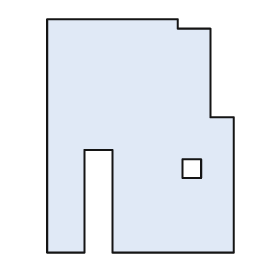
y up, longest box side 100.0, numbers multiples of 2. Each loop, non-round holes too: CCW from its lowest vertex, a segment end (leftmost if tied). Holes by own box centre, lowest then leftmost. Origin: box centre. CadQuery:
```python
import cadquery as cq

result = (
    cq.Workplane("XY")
    .moveTo(-40.0, -50.0)
    .lineTo(-24.0, -50.0)
    .lineTo(-24.0, -6.0)
    .lineTo(-12.0, -6.0)
    .lineTo(-12.0, -50.0)
    .lineTo(40.0, -50.0)
    .lineTo(40.0, 8.0)
    .lineTo(30.0, 8.0)
    .lineTo(30.0, 46.0)
    .lineTo(16.0, 46.0)
    .lineTo(16.0, 50.0)
    .lineTo(-40.0, 50.0)
    .close()
    .moveTo(18.0, -18.0)
    .lineTo(26.0, -18.0)
    .lineTo(26.0, -10.0)
    .lineTo(18.0, -10.0)
    .close()
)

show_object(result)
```